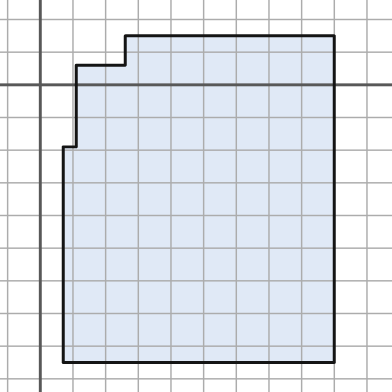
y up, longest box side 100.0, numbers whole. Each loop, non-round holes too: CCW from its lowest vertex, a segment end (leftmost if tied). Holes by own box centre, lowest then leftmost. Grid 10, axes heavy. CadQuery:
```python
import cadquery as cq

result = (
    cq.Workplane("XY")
    .moveTo(7.0, -85.0)
    .lineTo(90.0, -85.0)
    .lineTo(90.0, 15.0)
    .lineTo(26.0, 15.0)
    .lineTo(26.0, 6.0)
    .lineTo(11.0, 6.0)
    .lineTo(11.0, -19.0)
    .lineTo(7.0, -19.0)
    .close()
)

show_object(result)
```